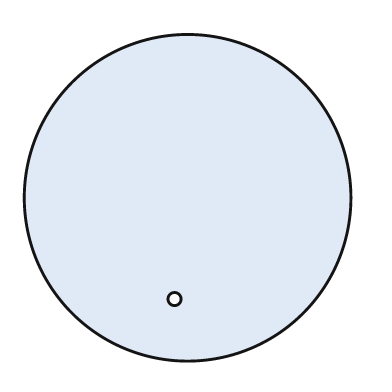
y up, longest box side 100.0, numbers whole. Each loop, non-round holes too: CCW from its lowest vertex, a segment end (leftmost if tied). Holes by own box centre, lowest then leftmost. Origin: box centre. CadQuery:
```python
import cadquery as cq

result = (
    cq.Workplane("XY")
    .moveTo(0.0, 0.0)
    .circle(50.0)
    .moveTo(-4.0, -31.0)
    .circle(2.0)
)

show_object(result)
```